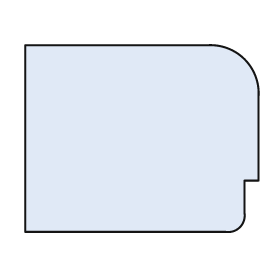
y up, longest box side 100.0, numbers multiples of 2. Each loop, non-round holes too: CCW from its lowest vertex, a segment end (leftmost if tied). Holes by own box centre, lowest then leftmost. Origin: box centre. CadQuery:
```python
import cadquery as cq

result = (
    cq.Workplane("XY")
    .moveTo(-50.0, -40.0)
    .lineTo(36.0, -40.0)
    .threePointArc((42.0, -38.0), (44.0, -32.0))
    .lineTo(44.0, -18.0)
    .lineTo(50.0, -18.0)
    .lineTo(50.0, 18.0)
    .threePointArc((44.0, 34.0), (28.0, 40.0))
    .lineTo(-50.0, 40.0)
    .close()
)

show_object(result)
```